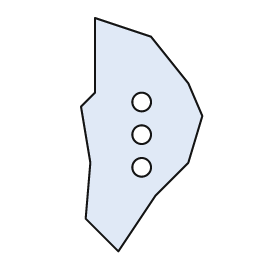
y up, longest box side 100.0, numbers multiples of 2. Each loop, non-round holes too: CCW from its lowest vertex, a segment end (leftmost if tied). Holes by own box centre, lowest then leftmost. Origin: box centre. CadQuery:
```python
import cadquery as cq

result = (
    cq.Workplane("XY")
    .moveTo(-10.0, -50.0)
    .lineTo(6.0, -26.0)
    .lineTo(20.0, -12.0)
    .lineTo(26.0, 8.0)
    .lineTo(20.0, 22.0)
    .lineTo(4.0, 42.0)
    .lineTo(-20.0, 50.0)
    .lineTo(-20.0, 18.0)
    .lineTo(-26.0, 12.0)
    .lineTo(-22.0, -12.0)
    .lineTo(-24.0, -36.0)
    .close()
    .moveTo(0.0, -14.0)
    .circle(4.0)
    .moveTo(0.0, 0.0)
    .circle(4.0)
    .moveTo(0.0, 14.0)
    .circle(4.0)
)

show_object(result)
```